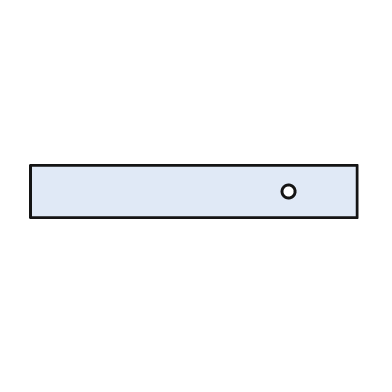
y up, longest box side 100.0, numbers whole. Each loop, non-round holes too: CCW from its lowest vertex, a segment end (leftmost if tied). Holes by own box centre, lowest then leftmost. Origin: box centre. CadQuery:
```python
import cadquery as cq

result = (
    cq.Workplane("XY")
    .moveTo(-50.0, -8.0)
    .lineTo(50.0, -8.0)
    .lineTo(50.0, 8.0)
    .lineTo(-50.0, 8.0)
    .close()
    .moveTo(29.0, 0.0)
    .circle(2.0)
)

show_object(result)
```